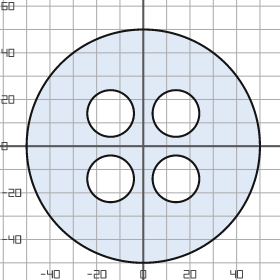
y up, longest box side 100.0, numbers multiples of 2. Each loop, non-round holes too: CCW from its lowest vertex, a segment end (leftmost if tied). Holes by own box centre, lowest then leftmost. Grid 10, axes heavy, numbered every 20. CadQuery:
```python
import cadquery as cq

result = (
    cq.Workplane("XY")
    .moveTo(0.0, 0.0)
    .circle(50.0)
    .moveTo(-14.0, -14.0)
    .circle(10.0)
    .moveTo(14.0, -14.0)
    .circle(10.0)
    .moveTo(-14.0, 14.0)
    .circle(10.0)
    .moveTo(14.0, 14.0)
    .circle(10.0)
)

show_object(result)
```